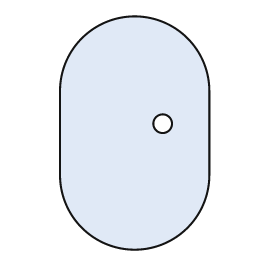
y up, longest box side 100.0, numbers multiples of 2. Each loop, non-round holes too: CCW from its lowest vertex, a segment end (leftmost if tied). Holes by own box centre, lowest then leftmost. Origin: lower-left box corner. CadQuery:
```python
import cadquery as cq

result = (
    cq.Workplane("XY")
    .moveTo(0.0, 32.0)
    .threePointArc((32.0, 0.0), (64.0, 32.0))
    .lineTo(64.0, 68.0)
    .threePointArc((32.0, 100.0), (0.0, 68.0))
    .close()
    .moveTo(44.0, 54.0)
    .circle(4.0)
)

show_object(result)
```